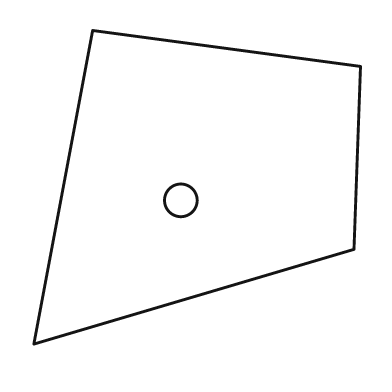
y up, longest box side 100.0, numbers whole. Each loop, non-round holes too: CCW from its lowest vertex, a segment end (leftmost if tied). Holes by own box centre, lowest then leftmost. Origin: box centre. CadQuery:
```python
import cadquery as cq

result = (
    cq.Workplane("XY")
    .moveTo(-50.0, -48.0)
    .lineTo(48.0, -19.0)
    .lineTo(50.0, 37.0)
    .lineTo(-32.0, 48.0)
    .close()
    .moveTo(-5.0, -4.0)
    .circle(5.0)
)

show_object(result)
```